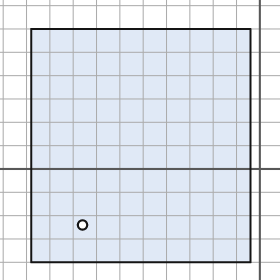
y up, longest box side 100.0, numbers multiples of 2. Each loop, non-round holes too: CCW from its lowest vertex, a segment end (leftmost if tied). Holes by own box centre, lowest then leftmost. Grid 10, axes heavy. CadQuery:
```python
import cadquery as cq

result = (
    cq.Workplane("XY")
    .moveTo(-98.0, -40.0)
    .lineTo(-4.0, -40.0)
    .lineTo(-4.0, 60.0)
    .lineTo(-98.0, 60.0)
    .close()
    .moveTo(-76.0, -24.0)
    .circle(2.0)
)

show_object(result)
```